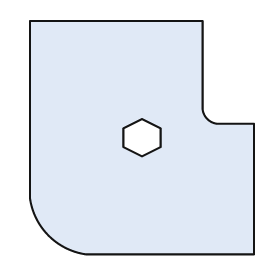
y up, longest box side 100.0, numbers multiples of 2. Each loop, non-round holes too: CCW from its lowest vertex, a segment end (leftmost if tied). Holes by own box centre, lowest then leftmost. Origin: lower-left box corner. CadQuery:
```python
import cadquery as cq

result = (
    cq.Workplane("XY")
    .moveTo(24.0, 0.0)
    .lineTo(96.0, 0.0)
    .lineTo(96.0, 56.0)
    .lineTo(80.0, 56.0)
    .threePointArc((76.0, 58.0), (74.0, 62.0))
    .lineTo(74.0, 100.0)
    .lineTo(0.0, 100.0)
    .lineTo(0.0, 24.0)
    .threePointArc((8.0, 8.0), (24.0, 0.0))
    .close()
    .moveTo(48.0, 42.0)
    .lineTo(56.0, 46.0)
    .lineTo(56.0, 54.0)
    .lineTo(48.0, 58.0)
    .lineTo(40.0, 54.0)
    .lineTo(40.0, 46.0)
    .close()
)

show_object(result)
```